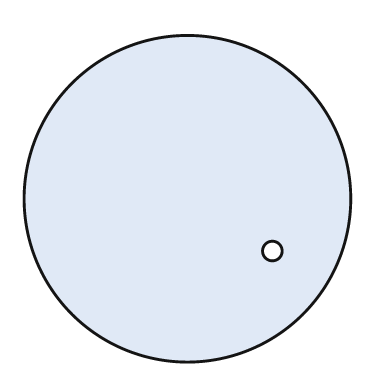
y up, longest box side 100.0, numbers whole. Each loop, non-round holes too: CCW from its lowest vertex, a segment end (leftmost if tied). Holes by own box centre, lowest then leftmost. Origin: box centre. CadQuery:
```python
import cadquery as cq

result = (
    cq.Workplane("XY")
    .moveTo(0.0, 0.0)
    .circle(50.0)
    .moveTo(26.0, -16.0)
    .circle(3.0)
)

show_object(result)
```